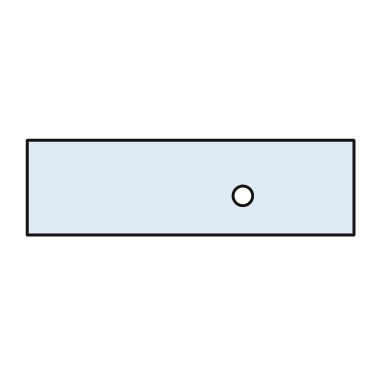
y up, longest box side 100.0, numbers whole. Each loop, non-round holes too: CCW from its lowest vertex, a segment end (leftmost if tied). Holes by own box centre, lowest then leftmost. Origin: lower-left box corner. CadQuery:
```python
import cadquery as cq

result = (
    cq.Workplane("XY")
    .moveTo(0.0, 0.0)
    .lineTo(100.0, 0.0)
    .lineTo(100.0, 29.0)
    .lineTo(0.0, 29.0)
    .close()
    .moveTo(66.0, 12.0)
    .circle(3.0)
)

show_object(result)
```